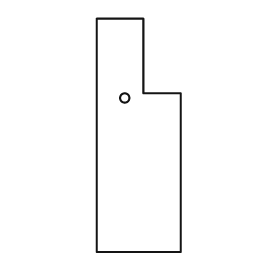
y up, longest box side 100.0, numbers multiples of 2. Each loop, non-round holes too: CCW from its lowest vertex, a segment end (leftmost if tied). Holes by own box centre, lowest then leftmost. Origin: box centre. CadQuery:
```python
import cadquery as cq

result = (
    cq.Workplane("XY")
    .moveTo(-18.0, -50.0)
    .lineTo(18.0, -50.0)
    .lineTo(18.0, 18.0)
    .lineTo(2.0, 18.0)
    .lineTo(2.0, 50.0)
    .lineTo(-18.0, 50.0)
    .close()
    .moveTo(-6.0, 16.0)
    .circle(2.0)
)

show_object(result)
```